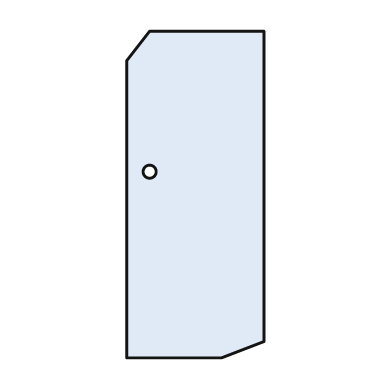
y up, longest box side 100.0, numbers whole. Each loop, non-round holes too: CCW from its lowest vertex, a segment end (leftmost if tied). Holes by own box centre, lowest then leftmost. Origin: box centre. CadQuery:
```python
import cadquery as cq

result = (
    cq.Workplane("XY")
    .moveTo(-21.0, -50.0)
    .lineTo(8.0, -50.0)
    .lineTo(21.0, -45.0)
    .lineTo(21.0, 50.0)
    .lineTo(-14.0, 50.0)
    .lineTo(-21.0, 41.0)
    .close()
    .moveTo(-14.0, 7.0)
    .circle(2.0)
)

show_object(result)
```